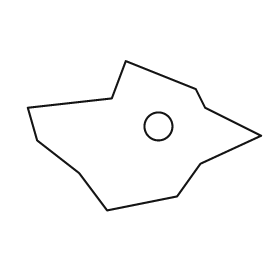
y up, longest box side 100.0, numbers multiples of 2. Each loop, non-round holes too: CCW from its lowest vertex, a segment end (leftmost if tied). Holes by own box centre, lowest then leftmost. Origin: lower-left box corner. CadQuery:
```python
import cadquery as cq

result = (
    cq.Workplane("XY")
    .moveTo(34.0, 0.0)
    .lineTo(64.0, 6.0)
    .lineTo(74.0, 20.0)
    .lineTo(100.0, 32.0)
    .lineTo(76.0, 44.0)
    .lineTo(72.0, 52.0)
    .lineTo(42.0, 64.0)
    .lineTo(36.0, 48.0)
    .lineTo(0.0, 44.0)
    .lineTo(4.0, 30.0)
    .lineTo(22.0, 16.0)
    .close()
    .moveTo(56.0, 36.0)
    .circle(6.0)
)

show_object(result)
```